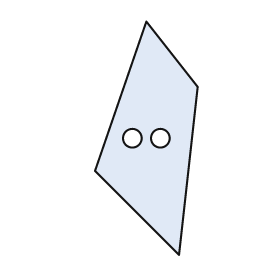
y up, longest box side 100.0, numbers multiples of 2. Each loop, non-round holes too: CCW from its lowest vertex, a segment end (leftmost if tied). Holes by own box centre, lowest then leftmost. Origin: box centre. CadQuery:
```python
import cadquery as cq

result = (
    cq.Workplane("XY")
    .moveTo(14.0, -50.0)
    .lineTo(22.0, 22.0)
    .lineTo(0.0, 50.0)
    .lineTo(-22.0, -14.0)
    .close()
    .moveTo(-6.0, 0.0)
    .circle(4.0)
    .moveTo(6.0, 0.0)
    .circle(4.0)
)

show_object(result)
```